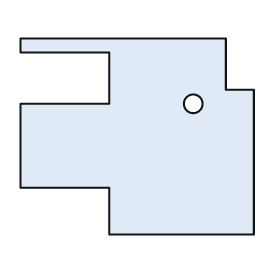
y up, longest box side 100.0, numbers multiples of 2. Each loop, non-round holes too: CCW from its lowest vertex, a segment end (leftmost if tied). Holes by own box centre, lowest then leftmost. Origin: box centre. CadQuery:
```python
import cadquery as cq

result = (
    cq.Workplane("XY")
    .moveTo(-12.0, -42.0)
    .lineTo(50.0, -42.0)
    .lineTo(50.0, 20.0)
    .lineTo(38.0, 20.0)
    .lineTo(38.0, 42.0)
    .lineTo(-50.0, 42.0)
    .lineTo(-50.0, 36.0)
    .lineTo(-12.0, 36.0)
    .lineTo(-12.0, 14.0)
    .lineTo(-50.0, 14.0)
    .lineTo(-50.0, -22.0)
    .lineTo(-12.0, -22.0)
    .close()
    .moveTo(24.0, 14.0)
    .circle(4.0)
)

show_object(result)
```